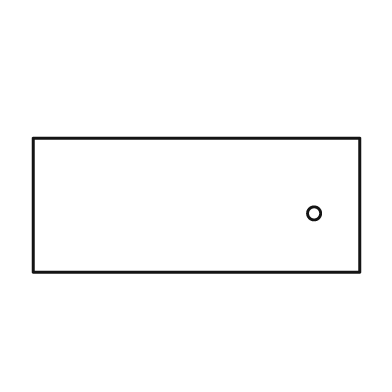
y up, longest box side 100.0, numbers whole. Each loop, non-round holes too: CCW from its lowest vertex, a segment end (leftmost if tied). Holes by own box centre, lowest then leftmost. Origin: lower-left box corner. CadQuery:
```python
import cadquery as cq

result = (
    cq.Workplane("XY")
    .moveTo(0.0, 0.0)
    .lineTo(100.0, 0.0)
    .lineTo(100.0, 41.0)
    .lineTo(0.0, 41.0)
    .close()
    .moveTo(86.0, 18.0)
    .circle(2.0)
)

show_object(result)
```